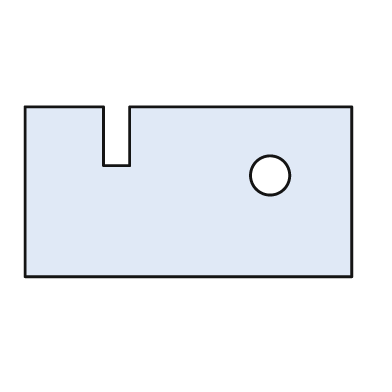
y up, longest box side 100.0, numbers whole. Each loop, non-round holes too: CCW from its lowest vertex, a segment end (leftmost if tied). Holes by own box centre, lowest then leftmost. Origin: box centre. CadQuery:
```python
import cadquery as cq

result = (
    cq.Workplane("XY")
    .moveTo(-50.0, -26.0)
    .lineTo(50.0, -26.0)
    .lineTo(50.0, 26.0)
    .lineTo(-18.0, 26.0)
    .lineTo(-18.0, 8.0)
    .lineTo(-26.0, 8.0)
    .lineTo(-26.0, 26.0)
    .lineTo(-50.0, 26.0)
    .close()
    .moveTo(25.0, 5.0)
    .circle(6.0)
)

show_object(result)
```